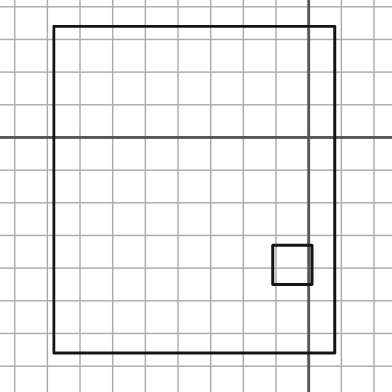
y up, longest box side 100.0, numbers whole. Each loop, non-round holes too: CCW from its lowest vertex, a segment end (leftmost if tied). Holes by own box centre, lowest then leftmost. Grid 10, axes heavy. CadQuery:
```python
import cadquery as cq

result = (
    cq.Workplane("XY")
    .moveTo(-78.0, -66.0)
    .lineTo(8.0, -66.0)
    .lineTo(8.0, 34.0)
    .lineTo(-78.0, 34.0)
    .close()
    .moveTo(-11.0, -45.0)
    .lineTo(1.0, -45.0)
    .lineTo(1.0, -33.0)
    .lineTo(-11.0, -33.0)
    .close()
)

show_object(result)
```